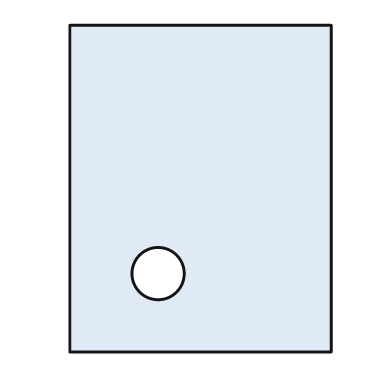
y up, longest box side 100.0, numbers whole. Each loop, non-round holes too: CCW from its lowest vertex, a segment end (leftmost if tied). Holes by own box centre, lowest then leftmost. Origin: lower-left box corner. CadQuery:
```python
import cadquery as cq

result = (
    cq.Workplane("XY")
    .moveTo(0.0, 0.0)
    .lineTo(80.0, 0.0)
    .lineTo(80.0, 100.0)
    .lineTo(0.0, 100.0)
    .close()
    .moveTo(27.0, 24.0)
    .circle(8.0)
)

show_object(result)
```